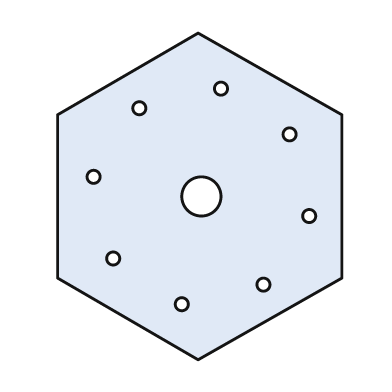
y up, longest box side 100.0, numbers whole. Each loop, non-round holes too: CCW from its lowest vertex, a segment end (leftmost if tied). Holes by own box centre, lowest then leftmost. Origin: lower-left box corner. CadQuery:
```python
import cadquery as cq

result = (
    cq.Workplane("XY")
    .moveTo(43.0, 0.0)
    .lineTo(87.0, 25.0)
    .lineTo(87.0, 75.0)
    .lineTo(43.0, 100.0)
    .lineTo(0.0, 75.0)
    .lineTo(0.0, 25.0)
    .close()
    .moveTo(38.0, 17.0)
    .circle(2.0)
    .moveTo(63.0, 23.0)
    .circle(2.0)
    .moveTo(17.0, 31.0)
    .circle(2.0)
    .moveTo(77.0, 44.0)
    .circle(2.0)
    .moveTo(44.0, 50.0)
    .circle(6.0)
    .moveTo(11.0, 56.0)
    .circle(2.0)
    .moveTo(71.0, 69.0)
    .circle(2.0)
    .moveTo(25.0, 77.0)
    .circle(2.0)
    .moveTo(50.0, 83.0)
    .circle(2.0)
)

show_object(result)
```